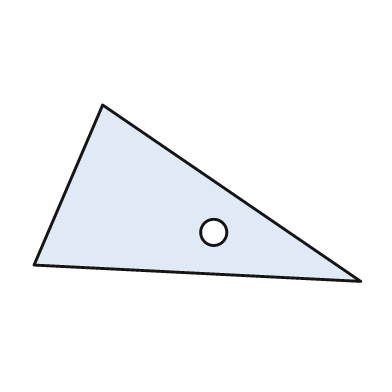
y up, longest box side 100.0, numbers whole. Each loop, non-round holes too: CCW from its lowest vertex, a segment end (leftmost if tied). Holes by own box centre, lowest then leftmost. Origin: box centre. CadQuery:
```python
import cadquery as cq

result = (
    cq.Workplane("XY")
    .moveTo(50.0, -27.0)
    .lineTo(-29.0, 27.0)
    .lineTo(-50.0, -22.0)
    .close()
    .moveTo(5.0, -12.0)
    .circle(4.0)
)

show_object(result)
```